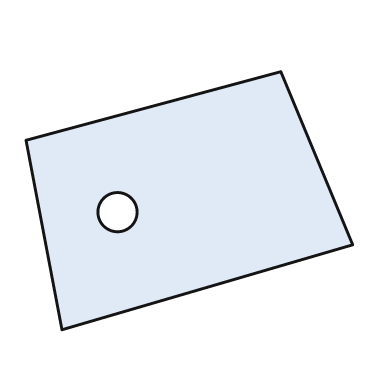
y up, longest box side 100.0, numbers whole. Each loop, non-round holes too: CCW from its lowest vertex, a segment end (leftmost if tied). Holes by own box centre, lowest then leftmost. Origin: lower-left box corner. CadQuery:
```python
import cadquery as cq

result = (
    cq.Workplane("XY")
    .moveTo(11.0, 0.0)
    .lineTo(100.0, 26.0)
    .lineTo(78.0, 79.0)
    .lineTo(0.0, 58.0)
    .close()
    .moveTo(28.0, 36.0)
    .circle(6.0)
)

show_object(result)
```